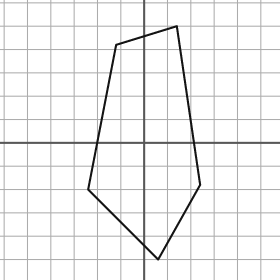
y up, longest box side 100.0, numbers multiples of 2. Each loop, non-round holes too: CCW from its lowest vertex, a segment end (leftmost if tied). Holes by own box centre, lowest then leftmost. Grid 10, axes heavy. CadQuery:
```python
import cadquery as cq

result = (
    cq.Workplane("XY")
    .moveTo(6.0, -50.0)
    .lineTo(24.0, -18.0)
    .lineTo(14.0, 50.0)
    .lineTo(-12.0, 42.0)
    .lineTo(-24.0, -20.0)
    .close()
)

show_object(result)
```